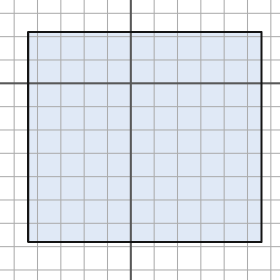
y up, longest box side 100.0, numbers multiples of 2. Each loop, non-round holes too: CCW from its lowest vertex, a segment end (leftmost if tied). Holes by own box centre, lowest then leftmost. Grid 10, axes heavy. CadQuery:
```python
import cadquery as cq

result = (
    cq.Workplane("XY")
    .moveTo(-44.0, -68.0)
    .lineTo(56.0, -68.0)
    .lineTo(56.0, 22.0)
    .lineTo(-44.0, 22.0)
    .close()
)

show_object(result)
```